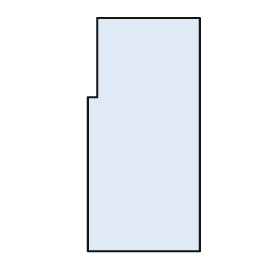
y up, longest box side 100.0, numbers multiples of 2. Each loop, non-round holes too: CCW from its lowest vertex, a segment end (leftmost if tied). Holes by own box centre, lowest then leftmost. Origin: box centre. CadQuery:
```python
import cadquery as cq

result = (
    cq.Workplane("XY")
    .moveTo(-24.0, -50.0)
    .lineTo(24.0, -50.0)
    .lineTo(24.0, 50.0)
    .lineTo(-20.0, 50.0)
    .lineTo(-20.0, 16.0)
    .lineTo(-24.0, 16.0)
    .close()
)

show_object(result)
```